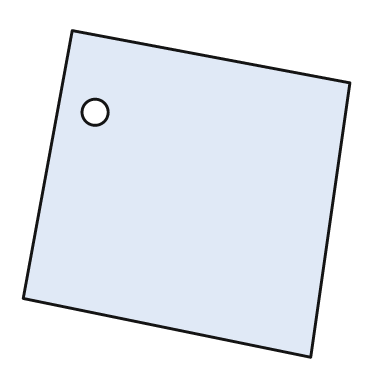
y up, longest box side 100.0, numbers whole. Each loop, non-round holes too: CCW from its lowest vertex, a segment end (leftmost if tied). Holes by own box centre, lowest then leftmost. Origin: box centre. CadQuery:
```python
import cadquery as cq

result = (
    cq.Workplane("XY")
    .moveTo(38.0, -50.0)
    .lineTo(50.0, 34.0)
    .lineTo(-35.0, 50.0)
    .lineTo(-50.0, -32.0)
    .close()
    .moveTo(-28.0, 25.0)
    .circle(4.0)
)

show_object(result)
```